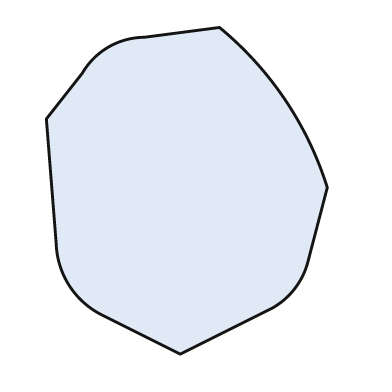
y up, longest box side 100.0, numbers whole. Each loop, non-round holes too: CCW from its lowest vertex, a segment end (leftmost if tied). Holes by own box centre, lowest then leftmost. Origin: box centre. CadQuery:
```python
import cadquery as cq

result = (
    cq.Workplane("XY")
    .moveTo(-2.0, -50.0)
    .lineTo(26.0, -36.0)
    .threePointArc((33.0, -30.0), (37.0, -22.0))
    .lineTo(43.0, 1.0)
    .threePointArc((30.0, 28.0), (10.0, 50.0))
    .lineTo(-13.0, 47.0)
    .threePointArc((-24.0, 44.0), (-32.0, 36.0))
    .lineTo(-43.0, 22.0)
    .lineTo(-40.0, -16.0)
    .threePointArc((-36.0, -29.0), (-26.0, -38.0))
    .close()
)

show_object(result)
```